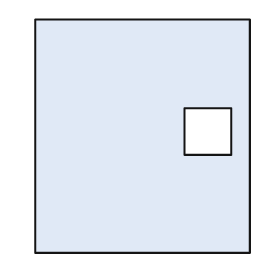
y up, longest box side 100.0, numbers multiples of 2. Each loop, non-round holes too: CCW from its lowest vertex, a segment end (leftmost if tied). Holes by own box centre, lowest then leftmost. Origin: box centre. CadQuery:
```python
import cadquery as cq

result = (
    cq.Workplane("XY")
    .moveTo(-46.0, -50.0)
    .lineTo(46.0, -50.0)
    .lineTo(46.0, 50.0)
    .lineTo(-46.0, 50.0)
    .close()
    .moveTo(18.0, -8.0)
    .lineTo(38.0, -8.0)
    .lineTo(38.0, 12.0)
    .lineTo(18.0, 12.0)
    .close()
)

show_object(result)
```